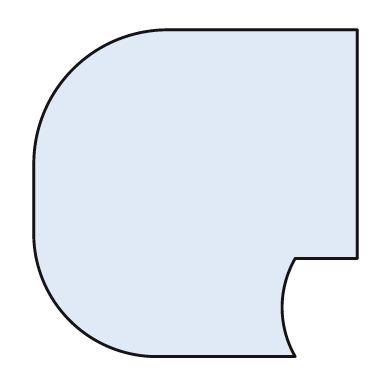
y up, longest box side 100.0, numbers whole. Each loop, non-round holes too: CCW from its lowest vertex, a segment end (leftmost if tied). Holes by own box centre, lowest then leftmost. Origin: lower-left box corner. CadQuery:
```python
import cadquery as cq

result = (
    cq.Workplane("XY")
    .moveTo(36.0, 0.0)
    .lineTo(80.0, 0.0)
    .threePointArc((76.0, 15.0), (80.0, 30.0))
    .lineTo(99.0, 30.0)
    .lineTo(99.0, 100.0)
    .lineTo(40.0, 100.0)
    .threePointArc((12.0, 88.0), (0.0, 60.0))
    .lineTo(0.0, 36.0)
    .threePointArc((11.0, 11.0), (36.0, 0.0))
    .close()
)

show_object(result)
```